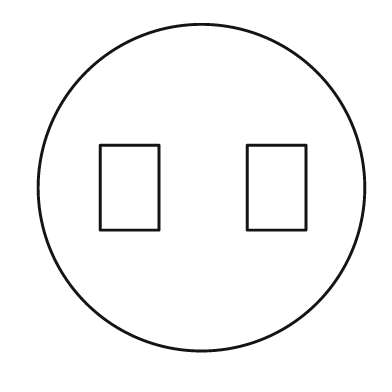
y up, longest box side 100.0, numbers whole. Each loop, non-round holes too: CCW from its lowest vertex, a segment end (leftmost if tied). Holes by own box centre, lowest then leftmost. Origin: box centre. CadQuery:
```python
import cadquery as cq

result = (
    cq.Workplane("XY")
    .moveTo(0.0, 0.0)
    .circle(50.0)
    .moveTo(-31.0, -13.0)
    .lineTo(-13.0, -13.0)
    .lineTo(-13.0, 13.0)
    .lineTo(-31.0, 13.0)
    .close()
    .moveTo(14.0, -13.0)
    .lineTo(32.0, -13.0)
    .lineTo(32.0, 13.0)
    .lineTo(14.0, 13.0)
    .close()
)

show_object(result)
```